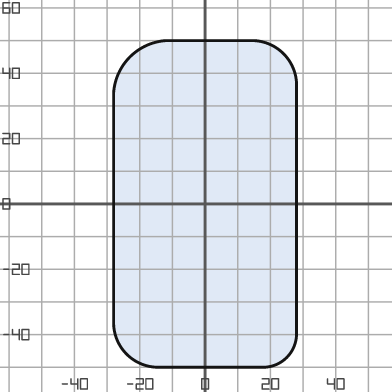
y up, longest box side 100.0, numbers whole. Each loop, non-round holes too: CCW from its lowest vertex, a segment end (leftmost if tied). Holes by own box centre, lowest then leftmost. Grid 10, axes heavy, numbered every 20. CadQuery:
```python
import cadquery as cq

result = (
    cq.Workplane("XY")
    .moveTo(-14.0, -50.0)
    .lineTo(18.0, -50.0)
    .threePointArc((25.0, -47.0), (28.0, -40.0))
    .lineTo(28.0, 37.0)
    .threePointArc((24.0, 46.0), (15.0, 50.0))
    .lineTo(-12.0, 50.0)
    .threePointArc((-23.0, 45.0), (-28.0, 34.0))
    .lineTo(-28.0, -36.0)
    .threePointArc((-24.0, -46.0), (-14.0, -50.0))
    .close()
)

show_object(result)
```